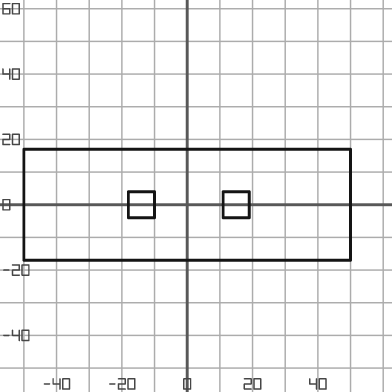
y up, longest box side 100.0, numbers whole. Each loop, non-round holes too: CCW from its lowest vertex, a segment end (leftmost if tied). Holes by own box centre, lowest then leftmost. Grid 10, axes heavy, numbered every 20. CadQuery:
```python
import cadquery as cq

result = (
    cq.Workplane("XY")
    .moveTo(-50.0, -17.0)
    .lineTo(50.0, -17.0)
    .lineTo(50.0, 17.0)
    .lineTo(-50.0, 17.0)
    .close()
    .moveTo(-18.0, -4.0)
    .lineTo(-10.0, -4.0)
    .lineTo(-10.0, 4.0)
    .lineTo(-18.0, 4.0)
    .close()
    .moveTo(11.0, -4.0)
    .lineTo(19.0, -4.0)
    .lineTo(19.0, 4.0)
    .lineTo(11.0, 4.0)
    .close()
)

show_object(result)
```